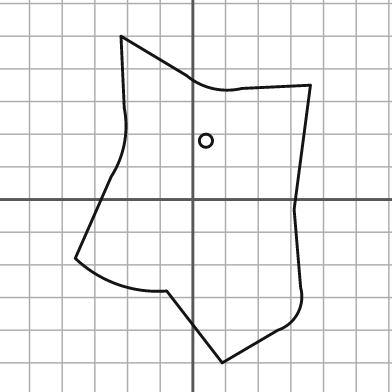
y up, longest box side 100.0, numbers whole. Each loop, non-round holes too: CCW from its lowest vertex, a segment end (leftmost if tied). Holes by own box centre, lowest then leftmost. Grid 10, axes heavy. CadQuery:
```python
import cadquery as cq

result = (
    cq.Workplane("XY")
    .moveTo(9.0, -50.0)
    .lineTo(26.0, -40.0)
    .threePointArc((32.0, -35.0), (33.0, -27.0))
    .lineTo(31.0, -3.0)
    .lineTo(36.0, 35.0)
    .lineTo(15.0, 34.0)
    .threePointArc((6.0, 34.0), (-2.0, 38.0))
    .lineTo(-22.0, 50.0)
    .lineTo(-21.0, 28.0)
    .threePointArc((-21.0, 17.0), (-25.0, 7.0))
    .lineTo(-36.0, -18.0)
    .threePointArc((-23.0, -26.0), (-8.0, -28.0))
    .close()
    .moveTo(4.0, 18.0)
    .circle(2.0)
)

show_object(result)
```